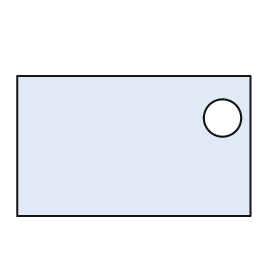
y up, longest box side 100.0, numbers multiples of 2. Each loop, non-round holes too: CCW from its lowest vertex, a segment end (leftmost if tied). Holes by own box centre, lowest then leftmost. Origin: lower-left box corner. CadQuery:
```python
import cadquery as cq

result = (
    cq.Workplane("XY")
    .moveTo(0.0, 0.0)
    .lineTo(100.0, 0.0)
    .lineTo(100.0, 60.0)
    .lineTo(0.0, 60.0)
    .close()
    .moveTo(88.0, 42.0)
    .circle(8.0)
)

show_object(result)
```